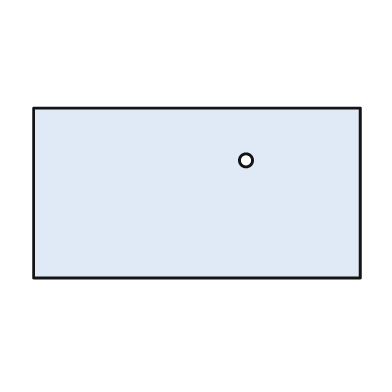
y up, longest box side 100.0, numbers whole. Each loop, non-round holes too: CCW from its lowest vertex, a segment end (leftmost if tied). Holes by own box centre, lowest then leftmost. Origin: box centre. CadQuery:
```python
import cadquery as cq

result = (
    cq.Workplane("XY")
    .moveTo(-50.0, -26.0)
    .lineTo(50.0, -26.0)
    .lineTo(50.0, 26.0)
    .lineTo(-50.0, 26.0)
    .close()
    .moveTo(15.0, 10.0)
    .circle(2.0)
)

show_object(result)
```